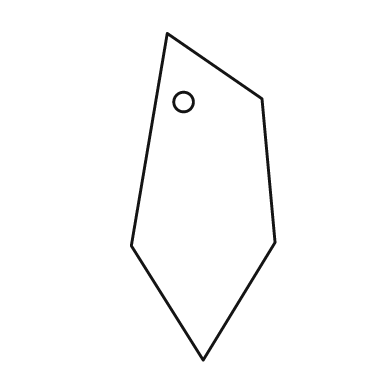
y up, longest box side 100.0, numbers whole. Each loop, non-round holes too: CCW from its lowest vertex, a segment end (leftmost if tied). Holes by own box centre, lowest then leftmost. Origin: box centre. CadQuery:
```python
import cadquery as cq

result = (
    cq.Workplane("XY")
    .moveTo(0.0, -50.0)
    .lineTo(22.0, -14.0)
    .lineTo(18.0, 30.0)
    .lineTo(-11.0, 50.0)
    .lineTo(-22.0, -15.0)
    .close()
    .moveTo(-6.0, 29.0)
    .circle(3.0)
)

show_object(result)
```